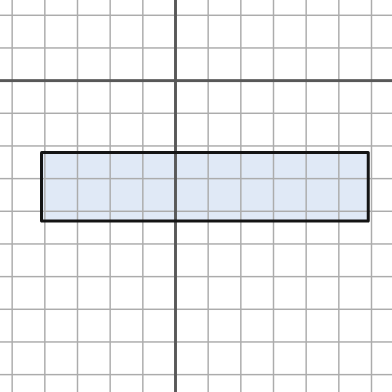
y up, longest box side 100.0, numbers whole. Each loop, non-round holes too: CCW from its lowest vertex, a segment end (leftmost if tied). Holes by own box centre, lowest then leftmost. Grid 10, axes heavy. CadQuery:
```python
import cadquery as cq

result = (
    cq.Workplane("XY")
    .moveTo(-41.0, -43.0)
    .lineTo(59.0, -43.0)
    .lineTo(59.0, -22.0)
    .lineTo(-41.0, -22.0)
    .close()
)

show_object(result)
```